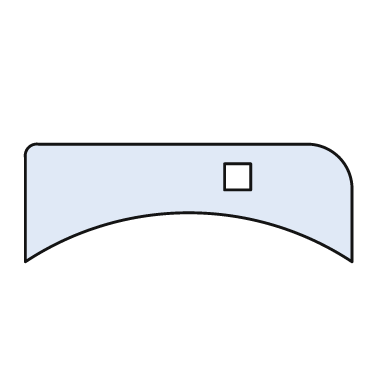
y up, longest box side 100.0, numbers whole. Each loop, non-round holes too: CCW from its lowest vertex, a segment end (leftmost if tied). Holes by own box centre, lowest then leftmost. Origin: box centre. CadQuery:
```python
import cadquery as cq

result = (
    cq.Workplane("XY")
    .moveTo(-50.0, -18.0)
    .threePointArc((0.0, -3.0), (50.0, -18.0))
    .lineTo(50.0, 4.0)
    .threePointArc((46.0, 14.0), (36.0, 18.0))
    .lineTo(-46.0, 18.0)
    .threePointArc((-49.0, 17.0), (-50.0, 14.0))
    .close()
    .moveTo(11.0, 4.0)
    .lineTo(19.0, 4.0)
    .lineTo(19.0, 12.0)
    .lineTo(11.0, 12.0)
    .close()
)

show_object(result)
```